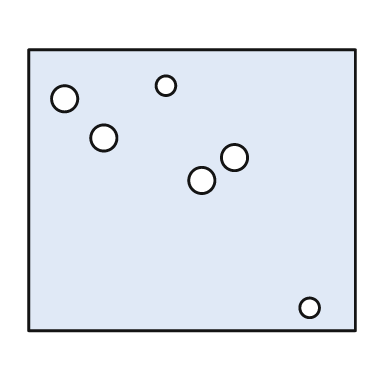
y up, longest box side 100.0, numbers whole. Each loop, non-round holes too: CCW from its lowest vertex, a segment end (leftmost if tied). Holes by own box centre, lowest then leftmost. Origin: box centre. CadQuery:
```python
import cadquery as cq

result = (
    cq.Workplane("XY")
    .moveTo(-50.0, -43.0)
    .lineTo(50.0, -43.0)
    .lineTo(50.0, 43.0)
    .lineTo(-50.0, 43.0)
    .close()
    .moveTo(36.0, -36.0)
    .circle(3.0)
    .moveTo(3.0, 3.0)
    .circle(4.0)
    .moveTo(13.0, 10.0)
    .circle(4.0)
    .moveTo(-27.0, 16.0)
    .circle(4.0)
    .moveTo(-39.0, 28.0)
    .circle(4.0)
    .moveTo(-8.0, 32.0)
    .circle(3.0)
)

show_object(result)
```